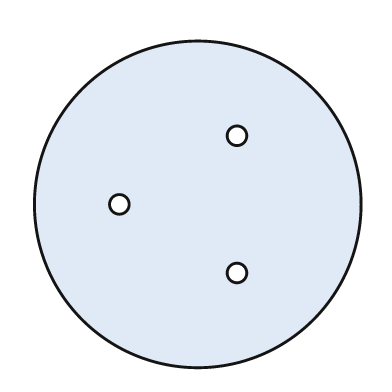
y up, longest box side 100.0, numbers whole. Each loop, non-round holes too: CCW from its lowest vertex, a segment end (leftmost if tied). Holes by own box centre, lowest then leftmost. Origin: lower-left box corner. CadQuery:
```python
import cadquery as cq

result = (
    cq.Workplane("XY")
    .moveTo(50.0, 50.0)
    .circle(50.0)
    .moveTo(62.0, 29.0)
    .circle(3.0)
    .moveTo(26.0, 50.0)
    .circle(3.0)
    .moveTo(62.0, 71.0)
    .circle(3.0)
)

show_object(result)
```